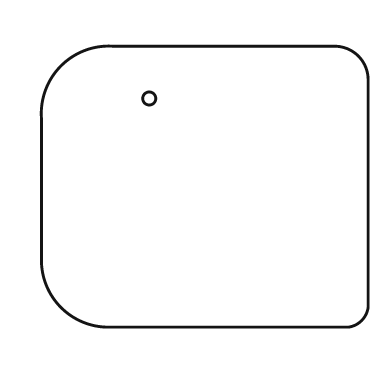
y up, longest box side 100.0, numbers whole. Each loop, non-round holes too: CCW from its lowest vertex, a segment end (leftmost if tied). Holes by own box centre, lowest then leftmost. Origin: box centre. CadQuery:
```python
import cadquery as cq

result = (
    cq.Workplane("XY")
    .moveTo(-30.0, -43.0)
    .lineTo(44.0, -43.0)
    .threePointArc((48.0, -41.0), (50.0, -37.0))
    .lineTo(50.0, 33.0)
    .threePointArc((47.0, 40.0), (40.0, 43.0))
    .lineTo(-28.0, 43.0)
    .threePointArc((-44.0, 37.0), (-50.0, 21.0))
    .lineTo(-50.0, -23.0)
    .threePointArc((-44.0, -37.0), (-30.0, -43.0))
    .close()
    .moveTo(-17.0, 27.0)
    .circle(2.0)
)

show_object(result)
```